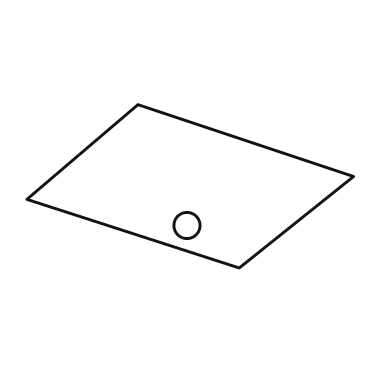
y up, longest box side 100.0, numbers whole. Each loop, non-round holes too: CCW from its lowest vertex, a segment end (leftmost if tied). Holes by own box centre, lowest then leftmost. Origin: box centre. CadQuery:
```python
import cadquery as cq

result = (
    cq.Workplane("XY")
    .moveTo(15.0, -25.0)
    .lineTo(50.0, 3.0)
    .lineTo(-16.0, 25.0)
    .lineTo(-50.0, -4.0)
    .close()
    .moveTo(-1.0, -12.0)
    .circle(4.0)
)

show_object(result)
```